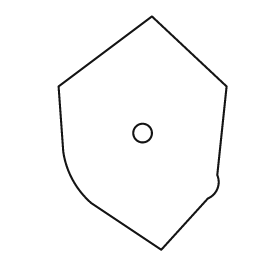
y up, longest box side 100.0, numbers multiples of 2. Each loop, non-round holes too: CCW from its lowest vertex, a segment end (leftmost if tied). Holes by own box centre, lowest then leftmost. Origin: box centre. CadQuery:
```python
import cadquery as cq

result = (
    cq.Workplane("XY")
    .moveTo(8.0, -50.0)
    .lineTo(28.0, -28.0)
    .threePointArc((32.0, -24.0), (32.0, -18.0))
    .lineTo(36.0, 20.0)
    .lineTo(4.0, 50.0)
    .lineTo(-36.0, 20.0)
    .lineTo(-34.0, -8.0)
    .threePointArc((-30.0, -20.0), (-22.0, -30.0))
    .close()
    .moveTo(0.0, 0.0)
    .circle(4.0)
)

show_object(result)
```